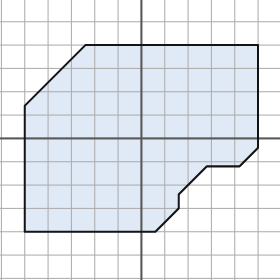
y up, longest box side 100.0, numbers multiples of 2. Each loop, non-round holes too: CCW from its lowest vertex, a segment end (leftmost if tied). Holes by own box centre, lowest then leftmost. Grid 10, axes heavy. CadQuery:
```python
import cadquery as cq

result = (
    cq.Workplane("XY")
    .moveTo(-50.0, -40.0)
    .lineTo(6.0, -40.0)
    .lineTo(16.0, -30.0)
    .lineTo(16.0, -24.0)
    .lineTo(28.0, -12.0)
    .lineTo(42.0, -12.0)
    .lineTo(50.0, -4.0)
    .lineTo(50.0, 40.0)
    .lineTo(-24.0, 40.0)
    .lineTo(-50.0, 14.0)
    .close()
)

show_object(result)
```